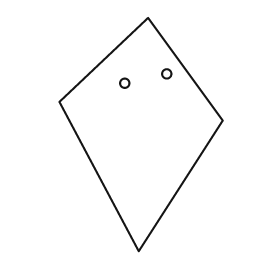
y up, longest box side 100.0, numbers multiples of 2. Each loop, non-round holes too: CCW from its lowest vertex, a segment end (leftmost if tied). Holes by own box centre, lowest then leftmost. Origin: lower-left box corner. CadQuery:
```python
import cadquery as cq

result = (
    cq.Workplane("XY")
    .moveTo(34.0, 0.0)
    .lineTo(70.0, 56.0)
    .lineTo(38.0, 100.0)
    .lineTo(0.0, 64.0)
    .close()
    .moveTo(28.0, 72.0)
    .circle(2.0)
    .moveTo(46.0, 76.0)
    .circle(2.0)
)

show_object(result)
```